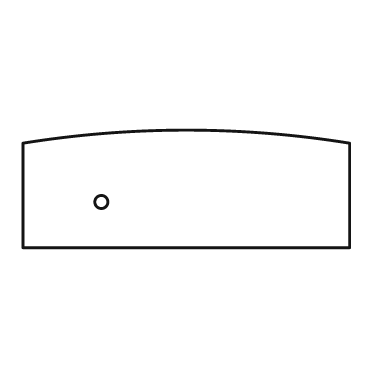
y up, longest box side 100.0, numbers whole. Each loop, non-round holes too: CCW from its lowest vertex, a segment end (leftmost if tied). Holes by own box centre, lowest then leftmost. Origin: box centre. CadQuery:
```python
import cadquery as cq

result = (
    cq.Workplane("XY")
    .moveTo(-50.0, -18.0)
    .lineTo(50.0, -18.0)
    .lineTo(50.0, 14.0)
    .threePointArc((0.0, 18.0), (-50.0, 14.0))
    .close()
    .moveTo(-26.0, -4.0)
    .circle(2.0)
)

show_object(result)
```